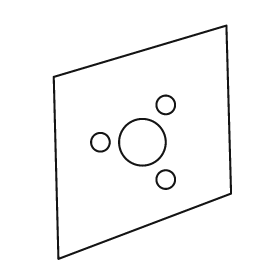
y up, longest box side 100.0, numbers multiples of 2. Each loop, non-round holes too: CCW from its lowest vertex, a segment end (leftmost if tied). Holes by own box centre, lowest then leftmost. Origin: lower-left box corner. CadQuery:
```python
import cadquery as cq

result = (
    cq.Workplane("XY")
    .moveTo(2.0, 0.0)
    .lineTo(76.0, 28.0)
    .lineTo(74.0, 100.0)
    .lineTo(0.0, 78.0)
    .close()
    .moveTo(48.0, 34.0)
    .circle(4.0)
    .moveTo(20.0, 50.0)
    .circle(4.0)
    .moveTo(38.0, 50.0)
    .circle(10.0)
    .moveTo(48.0, 66.0)
    .circle(4.0)
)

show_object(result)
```